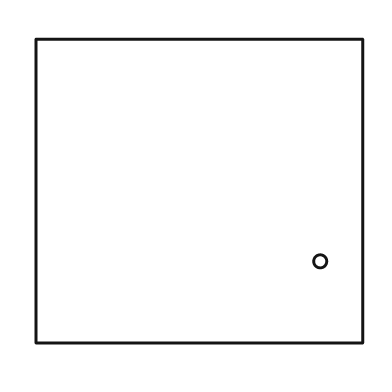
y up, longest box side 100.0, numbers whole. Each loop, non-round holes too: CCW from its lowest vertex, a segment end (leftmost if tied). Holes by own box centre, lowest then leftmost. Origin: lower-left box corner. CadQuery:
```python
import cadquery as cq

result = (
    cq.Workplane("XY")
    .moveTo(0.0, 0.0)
    .lineTo(100.0, 0.0)
    .lineTo(100.0, 93.0)
    .lineTo(0.0, 93.0)
    .close()
    .moveTo(87.0, 25.0)
    .circle(2.0)
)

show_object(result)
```